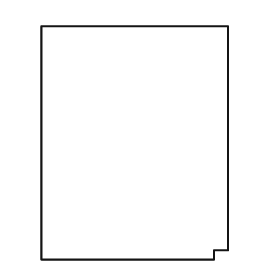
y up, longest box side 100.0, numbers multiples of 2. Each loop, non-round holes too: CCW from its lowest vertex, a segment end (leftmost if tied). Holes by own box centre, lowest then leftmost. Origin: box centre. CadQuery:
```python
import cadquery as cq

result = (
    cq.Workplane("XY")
    .moveTo(-40.0, -50.0)
    .lineTo(34.0, -50.0)
    .lineTo(34.0, -46.0)
    .lineTo(40.0, -46.0)
    .lineTo(40.0, 50.0)
    .lineTo(-40.0, 50.0)
    .close()
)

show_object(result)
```